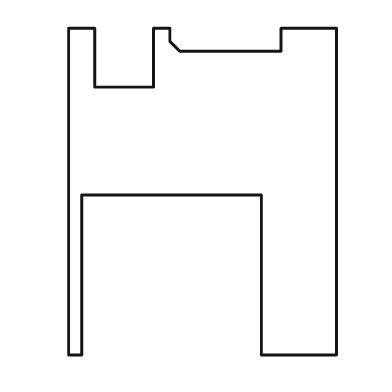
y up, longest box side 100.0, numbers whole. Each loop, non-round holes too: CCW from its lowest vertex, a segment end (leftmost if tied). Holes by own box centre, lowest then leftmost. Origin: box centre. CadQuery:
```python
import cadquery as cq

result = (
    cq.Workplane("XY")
    .moveTo(-41.0, -50.0)
    .lineTo(-37.0, -50.0)
    .lineTo(-37.0, -1.0)
    .lineTo(18.0, -1.0)
    .lineTo(18.0, -50.0)
    .lineTo(41.0, -50.0)
    .lineTo(41.0, 50.0)
    .lineTo(24.0, 50.0)
    .lineTo(24.0, 43.0)
    .lineTo(-7.0, 43.0)
    .lineTo(-10.0, 46.0)
    .lineTo(-10.0, 50.0)
    .lineTo(-15.0, 50.0)
    .lineTo(-15.0, 32.0)
    .lineTo(-33.0, 32.0)
    .lineTo(-33.0, 50.0)
    .lineTo(-41.0, 50.0)
    .close()
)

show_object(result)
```